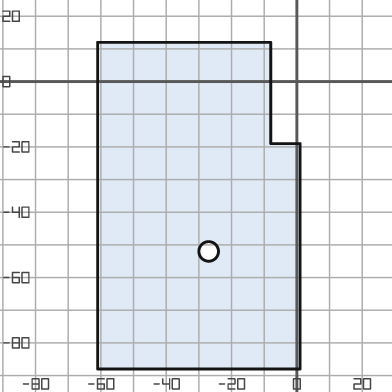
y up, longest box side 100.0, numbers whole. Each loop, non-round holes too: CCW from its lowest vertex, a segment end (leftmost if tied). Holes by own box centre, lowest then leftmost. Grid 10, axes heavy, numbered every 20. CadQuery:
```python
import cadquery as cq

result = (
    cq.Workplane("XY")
    .moveTo(-61.0, -88.0)
    .lineTo(1.0, -88.0)
    .lineTo(1.0, -19.0)
    .lineTo(-8.0, -19.0)
    .lineTo(-8.0, 12.0)
    .lineTo(-61.0, 12.0)
    .close()
    .moveTo(-27.0, -52.0)
    .circle(3.0)
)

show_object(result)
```